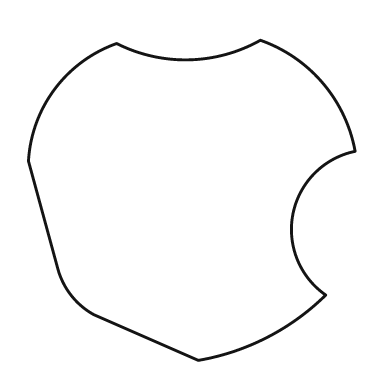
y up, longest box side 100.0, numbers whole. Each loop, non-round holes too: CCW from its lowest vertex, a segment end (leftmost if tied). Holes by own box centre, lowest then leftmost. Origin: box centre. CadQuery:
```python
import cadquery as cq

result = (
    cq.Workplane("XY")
    .moveTo(2.0, -49.0)
    .threePointArc((23.0, -42.0), (41.0, -29.0))
    .threePointArc((31.0, -4.0), (50.0, 15.0))
    .threePointArc((40.0, 36.0), (21.0, 49.0))
    .threePointArc((-1.0, 43.0), (-23.0, 48.0))
    .threePointArc((-42.0, 34.0), (-50.0, 12.0))
    .lineTo(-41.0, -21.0)
    .threePointArc((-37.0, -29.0), (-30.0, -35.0))
    .close()
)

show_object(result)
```